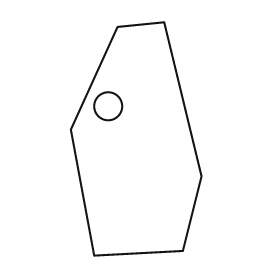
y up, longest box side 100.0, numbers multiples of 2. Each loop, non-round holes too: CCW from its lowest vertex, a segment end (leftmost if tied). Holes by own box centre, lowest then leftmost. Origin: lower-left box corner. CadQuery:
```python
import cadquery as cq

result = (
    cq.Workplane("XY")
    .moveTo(10.0, 0.0)
    .lineTo(48.0, 2.0)
    .lineTo(56.0, 34.0)
    .lineTo(40.0, 100.0)
    .lineTo(20.0, 98.0)
    .lineTo(0.0, 54.0)
    .close()
    .moveTo(16.0, 64.0)
    .circle(6.0)
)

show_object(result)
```